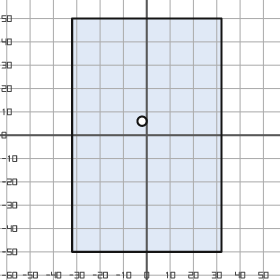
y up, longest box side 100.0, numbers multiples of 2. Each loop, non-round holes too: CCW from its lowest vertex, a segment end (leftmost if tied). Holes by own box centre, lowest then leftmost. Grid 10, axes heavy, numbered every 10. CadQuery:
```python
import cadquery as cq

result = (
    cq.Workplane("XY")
    .moveTo(-32.0, -50.0)
    .lineTo(32.0, -50.0)
    .lineTo(32.0, 50.0)
    .lineTo(-32.0, 50.0)
    .close()
    .moveTo(-2.0, 6.0)
    .circle(2.0)
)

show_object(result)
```